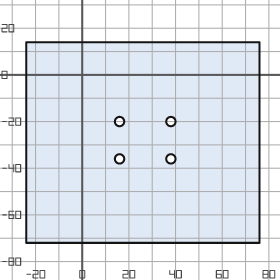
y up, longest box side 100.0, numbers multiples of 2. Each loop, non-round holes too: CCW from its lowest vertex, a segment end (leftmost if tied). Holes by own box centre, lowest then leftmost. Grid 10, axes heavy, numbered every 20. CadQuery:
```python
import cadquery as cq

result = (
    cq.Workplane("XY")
    .moveTo(-24.0, -72.0)
    .lineTo(76.0, -72.0)
    .lineTo(76.0, 14.0)
    .lineTo(-24.0, 14.0)
    .close()
    .moveTo(16.0, -36.0)
    .circle(2.0)
    .moveTo(38.0, -36.0)
    .circle(2.0)
    .moveTo(16.0, -20.0)
    .circle(2.0)
    .moveTo(38.0, -20.0)
    .circle(2.0)
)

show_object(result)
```